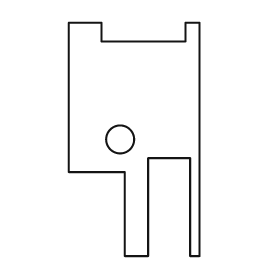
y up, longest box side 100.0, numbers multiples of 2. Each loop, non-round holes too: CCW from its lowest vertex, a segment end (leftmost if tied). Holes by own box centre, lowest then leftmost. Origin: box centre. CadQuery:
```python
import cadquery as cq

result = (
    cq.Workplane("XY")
    .moveTo(-4.0, -50.0)
    .lineTo(6.0, -50.0)
    .lineTo(6.0, -8.0)
    .lineTo(24.0, -8.0)
    .lineTo(24.0, -50.0)
    .lineTo(28.0, -50.0)
    .lineTo(28.0, 50.0)
    .lineTo(22.0, 50.0)
    .lineTo(22.0, 42.0)
    .lineTo(-14.0, 42.0)
    .lineTo(-14.0, 50.0)
    .lineTo(-28.0, 50.0)
    .lineTo(-28.0, -14.0)
    .lineTo(-4.0, -14.0)
    .close()
    .moveTo(-6.0, 0.0)
    .circle(6.0)
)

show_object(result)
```